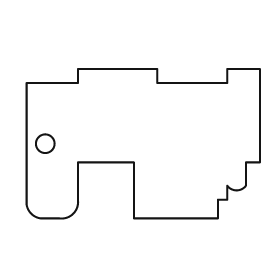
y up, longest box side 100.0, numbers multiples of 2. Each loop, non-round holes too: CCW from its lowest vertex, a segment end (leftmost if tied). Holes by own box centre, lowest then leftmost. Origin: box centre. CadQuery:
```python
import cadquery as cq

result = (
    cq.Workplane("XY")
    .moveTo(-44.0, -32.0)
    .lineTo(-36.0, -32.0)
    .threePointArc((-30.0, -30.0), (-28.0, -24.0))
    .lineTo(-28.0, -8.0)
    .lineTo(-4.0, -8.0)
    .lineTo(-4.0, -32.0)
    .lineTo(32.0, -32.0)
    .lineTo(32.0, -24.0)
    .lineTo(36.0, -24.0)
    .lineTo(36.0, -18.0)
    .threePointArc((40.0, -20.0), (44.0, -18.0))
    .lineTo(44.0, -8.0)
    .lineTo(50.0, -8.0)
    .lineTo(50.0, 32.0)
    .lineTo(36.0, 32.0)
    .lineTo(36.0, 26.0)
    .lineTo(6.0, 26.0)
    .lineTo(6.0, 32.0)
    .lineTo(-28.0, 32.0)
    .lineTo(-28.0, 26.0)
    .lineTo(-50.0, 26.0)
    .lineTo(-50.0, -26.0)
    .threePointArc((-48.0, -30.0), (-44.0, -32.0))
    .close()
    .moveTo(-42.0, 0.0)
    .circle(4.0)
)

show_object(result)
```